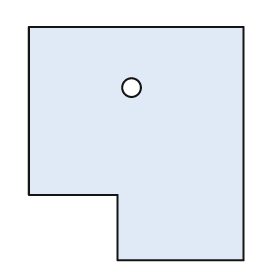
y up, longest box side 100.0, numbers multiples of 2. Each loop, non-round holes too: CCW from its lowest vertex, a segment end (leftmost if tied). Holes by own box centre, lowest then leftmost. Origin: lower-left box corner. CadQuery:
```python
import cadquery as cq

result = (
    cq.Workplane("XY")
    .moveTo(38.0, 0.0)
    .lineTo(92.0, 0.0)
    .lineTo(92.0, 100.0)
    .lineTo(0.0, 100.0)
    .lineTo(0.0, 28.0)
    .lineTo(38.0, 28.0)
    .close()
    .moveTo(44.0, 74.0)
    .circle(4.0)
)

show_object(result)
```